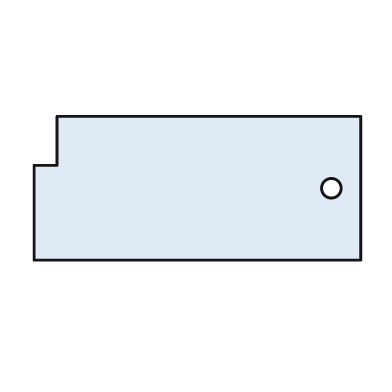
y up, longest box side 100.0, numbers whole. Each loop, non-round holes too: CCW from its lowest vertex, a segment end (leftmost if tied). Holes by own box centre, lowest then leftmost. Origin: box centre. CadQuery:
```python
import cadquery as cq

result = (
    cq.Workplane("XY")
    .moveTo(-50.0, -22.0)
    .lineTo(50.0, -22.0)
    .lineTo(50.0, 22.0)
    .lineTo(-43.0, 22.0)
    .lineTo(-43.0, 7.0)
    .lineTo(-50.0, 7.0)
    .close()
    .moveTo(41.0, 0.0)
    .circle(3.0)
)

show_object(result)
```